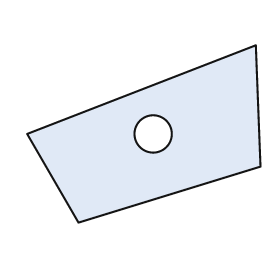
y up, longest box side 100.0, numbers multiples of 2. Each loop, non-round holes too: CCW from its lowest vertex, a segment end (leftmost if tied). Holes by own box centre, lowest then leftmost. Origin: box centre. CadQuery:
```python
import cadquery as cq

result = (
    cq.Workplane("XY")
    .moveTo(-28.0, -38.0)
    .lineTo(50.0, -14.0)
    .lineTo(48.0, 38.0)
    .lineTo(-50.0, 0.0)
    .close()
    .moveTo(4.0, 0.0)
    .circle(8.0)
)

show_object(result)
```